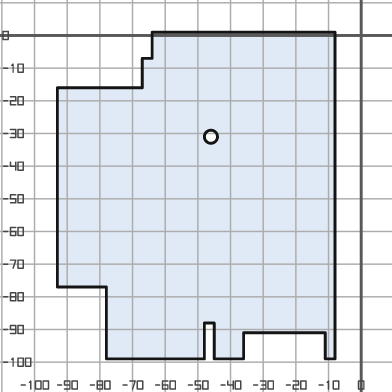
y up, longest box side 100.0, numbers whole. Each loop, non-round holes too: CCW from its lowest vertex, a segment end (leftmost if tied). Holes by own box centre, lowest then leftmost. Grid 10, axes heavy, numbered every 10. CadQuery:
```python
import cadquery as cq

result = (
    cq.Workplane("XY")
    .moveTo(-78.0, -99.0)
    .lineTo(-48.0, -99.0)
    .lineTo(-48.0, -88.0)
    .lineTo(-45.0, -88.0)
    .lineTo(-45.0, -99.0)
    .lineTo(-36.0, -99.0)
    .lineTo(-36.0, -91.0)
    .lineTo(-11.0, -91.0)
    .lineTo(-11.0, -99.0)
    .lineTo(-8.0, -99.0)
    .lineTo(-8.0, 1.0)
    .lineTo(-64.0, 1.0)
    .lineTo(-64.0, -7.0)
    .lineTo(-67.0, -7.0)
    .lineTo(-67.0, -16.0)
    .lineTo(-93.0, -16.0)
    .lineTo(-93.0, -77.0)
    .lineTo(-78.0, -77.0)
    .close()
    .moveTo(-46.0, -31.0)
    .circle(2.0)
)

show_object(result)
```